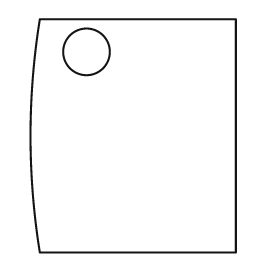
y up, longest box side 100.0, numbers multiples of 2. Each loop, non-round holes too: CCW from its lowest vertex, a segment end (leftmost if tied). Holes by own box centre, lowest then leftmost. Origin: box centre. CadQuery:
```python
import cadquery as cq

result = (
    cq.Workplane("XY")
    .moveTo(-40.0, -50.0)
    .lineTo(44.0, -50.0)
    .lineTo(44.0, 50.0)
    .lineTo(-40.0, 50.0)
    .threePointArc((-44.0, 0.0), (-40.0, -50.0))
    .close()
    .moveTo(-20.0, 36.0)
    .circle(10.0)
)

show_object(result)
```